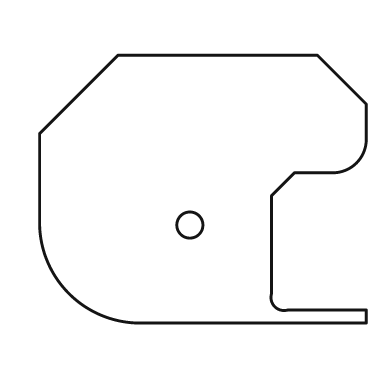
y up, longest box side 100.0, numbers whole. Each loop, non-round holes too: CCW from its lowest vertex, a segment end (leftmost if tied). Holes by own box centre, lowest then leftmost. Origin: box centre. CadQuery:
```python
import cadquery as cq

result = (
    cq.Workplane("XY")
    .moveTo(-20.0, -41.0)
    .lineTo(50.0, -41.0)
    .lineTo(50.0, -37.0)
    .lineTo(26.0, -37.0)
    .threePointArc((22.0, -36.0), (21.0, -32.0))
    .lineTo(21.0, -2.0)
    .lineTo(28.0, 5.0)
    .lineTo(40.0, 5.0)
    .threePointArc((47.0, 8.0), (50.0, 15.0))
    .lineTo(50.0, 26.0)
    .lineTo(35.0, 41.0)
    .lineTo(-26.0, 41.0)
    .lineTo(-50.0, 17.0)
    .lineTo(-50.0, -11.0)
    .threePointArc((-41.0, -32.0), (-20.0, -41.0))
    .close()
    .moveTo(-4.0, -11.0)
    .circle(4.0)
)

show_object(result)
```